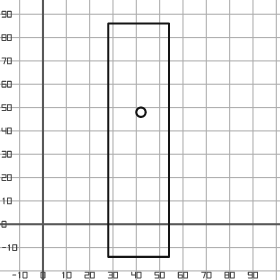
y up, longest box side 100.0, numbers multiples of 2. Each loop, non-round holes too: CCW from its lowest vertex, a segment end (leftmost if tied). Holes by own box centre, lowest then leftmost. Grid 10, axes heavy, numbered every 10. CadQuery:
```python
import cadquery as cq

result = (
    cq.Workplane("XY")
    .moveTo(28.0, -14.0)
    .lineTo(54.0, -14.0)
    .lineTo(54.0, 86.0)
    .lineTo(28.0, 86.0)
    .close()
    .moveTo(42.0, 48.0)
    .circle(2.0)
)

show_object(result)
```